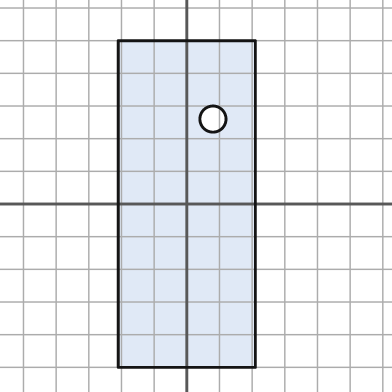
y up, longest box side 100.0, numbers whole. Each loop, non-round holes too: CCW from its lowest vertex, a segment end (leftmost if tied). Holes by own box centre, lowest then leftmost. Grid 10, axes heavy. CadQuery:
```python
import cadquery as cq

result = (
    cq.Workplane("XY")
    .moveTo(-21.0, -50.0)
    .lineTo(21.0, -50.0)
    .lineTo(21.0, 50.0)
    .lineTo(-21.0, 50.0)
    .close()
    .moveTo(8.0, 26.0)
    .circle(4.0)
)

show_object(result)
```